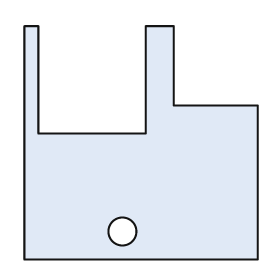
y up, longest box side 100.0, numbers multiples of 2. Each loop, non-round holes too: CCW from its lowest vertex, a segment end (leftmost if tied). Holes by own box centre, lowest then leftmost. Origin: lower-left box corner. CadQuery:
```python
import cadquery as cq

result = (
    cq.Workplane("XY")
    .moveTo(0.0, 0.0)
    .lineTo(100.0, 0.0)
    .lineTo(100.0, 66.0)
    .lineTo(64.0, 66.0)
    .lineTo(64.0, 100.0)
    .lineTo(52.0, 100.0)
    .lineTo(52.0, 54.0)
    .lineTo(6.0, 54.0)
    .lineTo(6.0, 100.0)
    .lineTo(0.0, 100.0)
    .close()
    .moveTo(42.0, 12.0)
    .circle(6.0)
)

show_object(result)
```